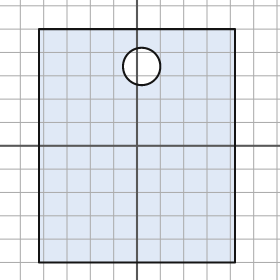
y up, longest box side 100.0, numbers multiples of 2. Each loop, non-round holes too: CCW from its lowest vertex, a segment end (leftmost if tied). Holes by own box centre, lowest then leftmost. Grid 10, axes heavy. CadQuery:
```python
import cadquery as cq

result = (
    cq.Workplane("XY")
    .moveTo(-42.0, -50.0)
    .lineTo(42.0, -50.0)
    .lineTo(42.0, 50.0)
    .lineTo(-42.0, 50.0)
    .close()
    .moveTo(2.0, 34.0)
    .circle(8.0)
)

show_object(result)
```